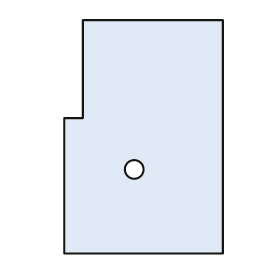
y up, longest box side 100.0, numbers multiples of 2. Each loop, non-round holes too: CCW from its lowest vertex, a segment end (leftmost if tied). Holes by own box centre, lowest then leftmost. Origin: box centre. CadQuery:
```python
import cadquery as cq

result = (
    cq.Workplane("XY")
    .moveTo(-34.0, -50.0)
    .lineTo(34.0, -50.0)
    .lineTo(34.0, 50.0)
    .lineTo(-26.0, 50.0)
    .lineTo(-26.0, 8.0)
    .lineTo(-34.0, 8.0)
    .close()
    .moveTo(-4.0, -14.0)
    .circle(4.0)
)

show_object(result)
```